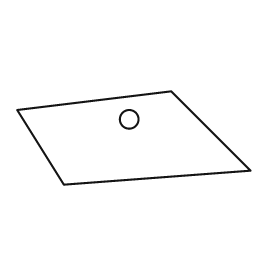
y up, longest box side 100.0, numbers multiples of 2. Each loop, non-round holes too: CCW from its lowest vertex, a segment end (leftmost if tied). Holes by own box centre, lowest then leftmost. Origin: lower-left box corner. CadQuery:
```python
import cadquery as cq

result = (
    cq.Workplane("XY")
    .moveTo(20.0, 0.0)
    .lineTo(100.0, 6.0)
    .lineTo(66.0, 40.0)
    .lineTo(0.0, 32.0)
    .close()
    .moveTo(48.0, 28.0)
    .circle(4.0)
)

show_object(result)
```